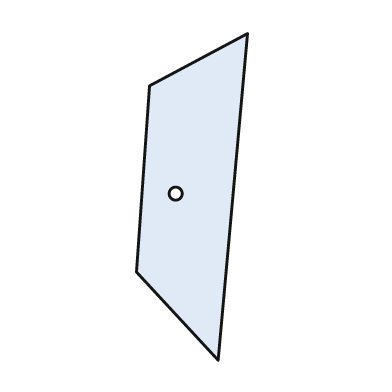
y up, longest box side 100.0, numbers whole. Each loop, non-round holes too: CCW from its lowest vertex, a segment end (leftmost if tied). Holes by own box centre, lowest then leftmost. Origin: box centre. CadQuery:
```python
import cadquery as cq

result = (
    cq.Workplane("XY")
    .moveTo(8.0, -50.0)
    .lineTo(17.0, 50.0)
    .lineTo(-13.0, 34.0)
    .lineTo(-17.0, -23.0)
    .close()
    .moveTo(-5.0, 1.0)
    .circle(2.0)
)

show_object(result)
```